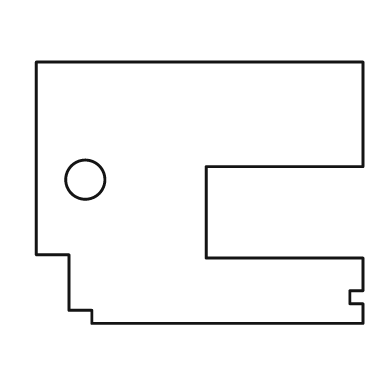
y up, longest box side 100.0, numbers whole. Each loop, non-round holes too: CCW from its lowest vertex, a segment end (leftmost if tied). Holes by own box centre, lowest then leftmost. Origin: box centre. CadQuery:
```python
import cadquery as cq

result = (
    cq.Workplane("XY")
    .moveTo(-33.0, -40.0)
    .lineTo(50.0, -40.0)
    .lineTo(50.0, -34.0)
    .lineTo(46.0, -34.0)
    .lineTo(46.0, -30.0)
    .lineTo(50.0, -30.0)
    .lineTo(50.0, -20.0)
    .lineTo(2.0, -20.0)
    .lineTo(2.0, 8.0)
    .lineTo(50.0, 8.0)
    .lineTo(50.0, 40.0)
    .lineTo(-50.0, 40.0)
    .lineTo(-50.0, -19.0)
    .lineTo(-40.0, -19.0)
    .lineTo(-40.0, -36.0)
    .lineTo(-33.0, -36.0)
    .close()
    .moveTo(-35.0, 4.0)
    .circle(6.0)
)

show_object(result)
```